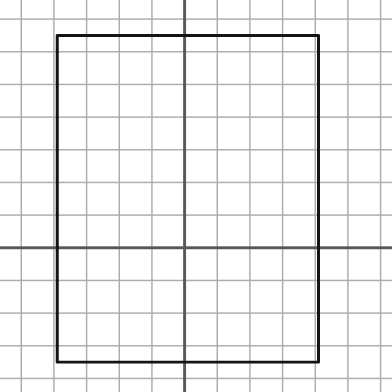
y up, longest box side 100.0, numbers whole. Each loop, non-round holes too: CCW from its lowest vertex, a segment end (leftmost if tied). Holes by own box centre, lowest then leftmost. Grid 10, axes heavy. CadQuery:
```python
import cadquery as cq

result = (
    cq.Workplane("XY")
    .moveTo(-39.0, -35.0)
    .lineTo(41.0, -35.0)
    .lineTo(41.0, 65.0)
    .lineTo(-39.0, 65.0)
    .close()
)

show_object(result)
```